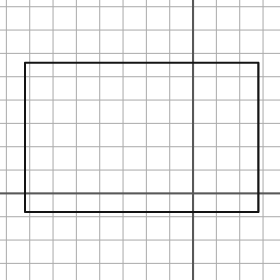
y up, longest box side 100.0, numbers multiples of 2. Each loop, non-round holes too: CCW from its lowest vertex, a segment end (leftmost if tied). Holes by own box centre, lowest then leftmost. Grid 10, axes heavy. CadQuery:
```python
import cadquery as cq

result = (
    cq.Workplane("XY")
    .moveTo(-72.0, -8.0)
    .lineTo(28.0, -8.0)
    .lineTo(28.0, 56.0)
    .lineTo(-72.0, 56.0)
    .close()
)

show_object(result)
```